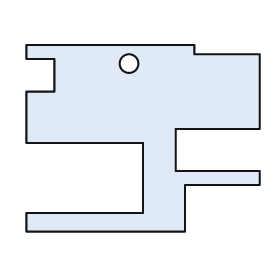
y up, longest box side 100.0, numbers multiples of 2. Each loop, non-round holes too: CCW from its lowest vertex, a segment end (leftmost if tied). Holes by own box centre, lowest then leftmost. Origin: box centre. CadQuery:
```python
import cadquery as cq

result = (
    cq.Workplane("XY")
    .moveTo(-50.0, -40.0)
    .lineTo(18.0, -40.0)
    .lineTo(18.0, -20.0)
    .lineTo(50.0, -20.0)
    .lineTo(50.0, -14.0)
    .lineTo(14.0, -14.0)
    .lineTo(14.0, 4.0)
    .lineTo(50.0, 4.0)
    .lineTo(50.0, 36.0)
    .lineTo(22.0, 36.0)
    .lineTo(22.0, 40.0)
    .lineTo(-50.0, 40.0)
    .lineTo(-50.0, 34.0)
    .lineTo(-38.0, 34.0)
    .lineTo(-38.0, 20.0)
    .lineTo(-50.0, 20.0)
    .lineTo(-50.0, -2.0)
    .lineTo(0.0, -2.0)
    .lineTo(0.0, -32.0)
    .lineTo(-50.0, -32.0)
    .close()
    .moveTo(-6.0, 32.0)
    .circle(4.0)
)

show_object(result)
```